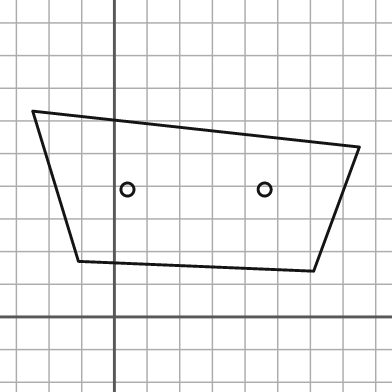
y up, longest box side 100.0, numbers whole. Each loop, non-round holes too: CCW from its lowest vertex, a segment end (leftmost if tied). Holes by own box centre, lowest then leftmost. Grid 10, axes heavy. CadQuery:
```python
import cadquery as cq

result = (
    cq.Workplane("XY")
    .moveTo(61.0, 14.0)
    .lineTo(75.0, 52.0)
    .lineTo(-25.0, 63.0)
    .lineTo(-11.0, 17.0)
    .close()
    .moveTo(4.0, 39.0)
    .circle(2.0)
    .moveTo(46.0, 39.0)
    .circle(2.0)
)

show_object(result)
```